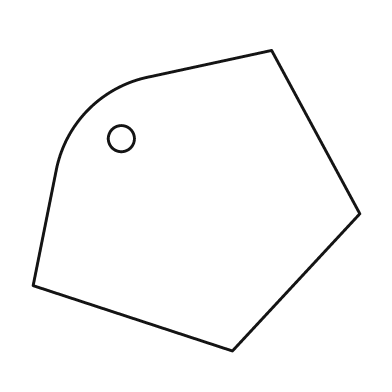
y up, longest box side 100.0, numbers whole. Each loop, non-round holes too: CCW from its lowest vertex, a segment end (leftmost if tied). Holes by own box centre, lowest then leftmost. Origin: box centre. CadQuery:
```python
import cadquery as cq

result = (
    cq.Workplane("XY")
    .moveTo(11.0, -46.0)
    .lineTo(50.0, -4.0)
    .lineTo(23.0, 46.0)
    .lineTo(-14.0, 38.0)
    .threePointArc((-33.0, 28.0), (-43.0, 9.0))
    .lineTo(-50.0, -26.0)
    .close()
    .moveTo(-23.0, 19.0)
    .circle(4.0)
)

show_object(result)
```